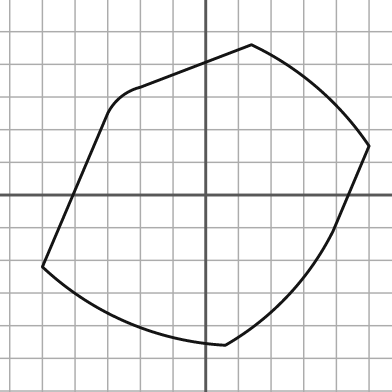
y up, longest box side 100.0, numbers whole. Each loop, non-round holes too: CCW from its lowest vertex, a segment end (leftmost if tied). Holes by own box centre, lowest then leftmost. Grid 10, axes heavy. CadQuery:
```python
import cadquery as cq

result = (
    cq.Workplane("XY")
    .moveTo(6.0, -46.0)
    .threePointArc((25.0, -31.0), (39.0, -11.0))
    .lineTo(50.0, 15.0)
    .threePointArc((34.0, 33.0), (14.0, 46.0))
    .lineTo(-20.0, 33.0)
    .threePointArc((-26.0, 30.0), (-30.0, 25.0))
    .lineTo(-50.0, -22.0)
    .threePointArc((-24.0, -39.0), (6.0, -46.0))
    .close()
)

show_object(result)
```